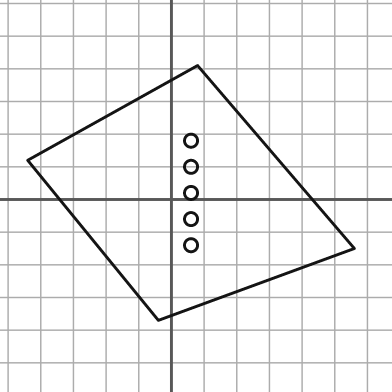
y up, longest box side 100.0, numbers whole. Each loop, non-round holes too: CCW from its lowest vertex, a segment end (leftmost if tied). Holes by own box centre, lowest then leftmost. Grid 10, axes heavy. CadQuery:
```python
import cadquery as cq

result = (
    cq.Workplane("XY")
    .moveTo(-4.0, -37.0)
    .lineTo(56.0, -15.0)
    .lineTo(8.0, 41.0)
    .lineTo(-44.0, 12.0)
    .close()
    .moveTo(6.0, -14.0)
    .circle(2.0)
    .moveTo(6.0, -6.0)
    .circle(2.0)
    .moveTo(6.0, 2.0)
    .circle(2.0)
    .moveTo(6.0, 10.0)
    .circle(2.0)
    .moveTo(6.0, 18.0)
    .circle(2.0)
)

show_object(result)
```